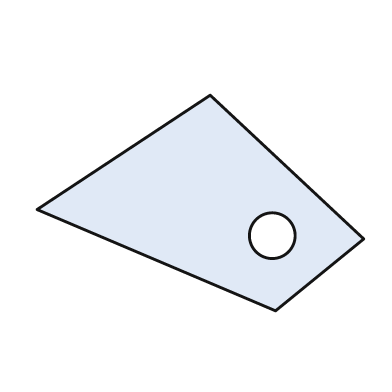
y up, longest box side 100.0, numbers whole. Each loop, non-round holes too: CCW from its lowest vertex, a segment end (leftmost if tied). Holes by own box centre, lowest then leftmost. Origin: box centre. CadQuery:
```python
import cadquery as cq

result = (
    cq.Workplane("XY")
    .moveTo(23.0, -33.0)
    .lineTo(50.0, -11.0)
    .lineTo(3.0, 33.0)
    .lineTo(-50.0, -2.0)
    .close()
    .moveTo(22.0, -10.0)
    .circle(7.0)
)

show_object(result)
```